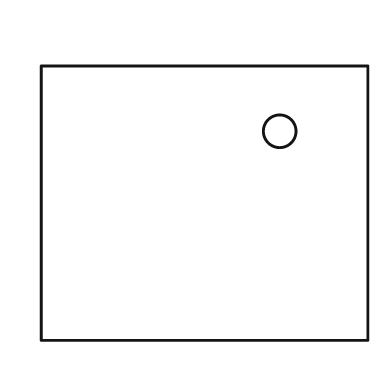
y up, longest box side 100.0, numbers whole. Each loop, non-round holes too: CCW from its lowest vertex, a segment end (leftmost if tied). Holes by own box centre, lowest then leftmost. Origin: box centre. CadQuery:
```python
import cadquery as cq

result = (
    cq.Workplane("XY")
    .moveTo(-50.0, -42.0)
    .lineTo(50.0, -42.0)
    .lineTo(50.0, 42.0)
    .lineTo(-50.0, 42.0)
    .close()
    .moveTo(23.0, 22.0)
    .circle(5.0)
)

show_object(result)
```